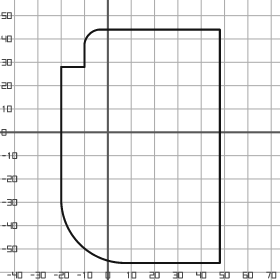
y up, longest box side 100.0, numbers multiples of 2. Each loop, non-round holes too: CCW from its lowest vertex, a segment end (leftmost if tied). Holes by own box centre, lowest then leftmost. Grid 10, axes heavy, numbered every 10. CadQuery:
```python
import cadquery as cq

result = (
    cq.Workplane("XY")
    .moveTo(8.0, -56.0)
    .lineTo(48.0, -56.0)
    .lineTo(48.0, 44.0)
    .lineTo(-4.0, 44.0)
    .threePointArc((-8.0, 42.0), (-10.0, 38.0))
    .lineTo(-10.0, 28.0)
    .lineTo(-20.0, 28.0)
    .lineTo(-20.0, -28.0)
    .threePointArc((-12.0, -48.0), (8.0, -56.0))
    .close()
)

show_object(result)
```